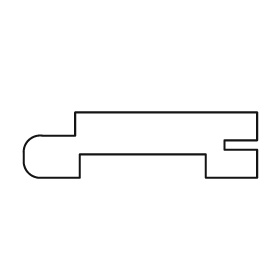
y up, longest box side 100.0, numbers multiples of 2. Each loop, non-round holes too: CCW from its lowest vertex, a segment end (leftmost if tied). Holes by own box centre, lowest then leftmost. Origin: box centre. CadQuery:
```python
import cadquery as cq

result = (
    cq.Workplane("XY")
    .moveTo(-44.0, -14.0)
    .lineTo(-26.0, -14.0)
    .lineTo(-26.0, -4.0)
    .lineTo(28.0, -4.0)
    .lineTo(28.0, -14.0)
    .lineTo(50.0, -14.0)
    .lineTo(50.0, -2.0)
    .lineTo(36.0, -2.0)
    .lineTo(36.0, 2.0)
    .lineTo(50.0, 2.0)
    .lineTo(50.0, 14.0)
    .lineTo(-28.0, 14.0)
    .lineTo(-28.0, 4.0)
    .lineTo(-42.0, 4.0)
    .threePointArc((-48.0, 2.0), (-50.0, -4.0))
    .lineTo(-50.0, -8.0)
    .threePointArc((-48.0, -12.0), (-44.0, -14.0))
    .close()
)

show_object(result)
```